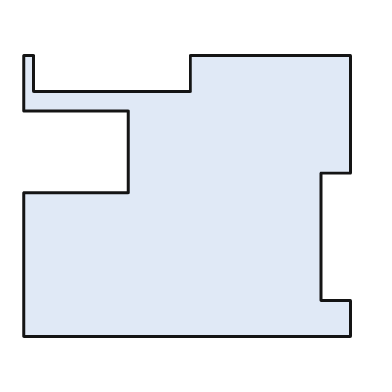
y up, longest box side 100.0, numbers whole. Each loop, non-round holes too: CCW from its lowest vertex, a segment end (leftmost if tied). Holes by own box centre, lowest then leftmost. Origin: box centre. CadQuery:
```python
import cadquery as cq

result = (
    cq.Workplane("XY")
    .moveTo(-50.0, -43.0)
    .lineTo(50.0, -43.0)
    .lineTo(50.0, -32.0)
    .lineTo(41.0, -32.0)
    .lineTo(41.0, 7.0)
    .lineTo(50.0, 7.0)
    .lineTo(50.0, 43.0)
    .lineTo(1.0, 43.0)
    .lineTo(1.0, 32.0)
    .lineTo(-47.0, 32.0)
    .lineTo(-47.0, 43.0)
    .lineTo(-50.0, 43.0)
    .lineTo(-50.0, 26.0)
    .lineTo(-18.0, 26.0)
    .lineTo(-18.0, 1.0)
    .lineTo(-50.0, 1.0)
    .close()
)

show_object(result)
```